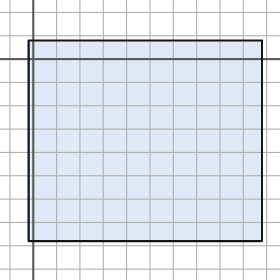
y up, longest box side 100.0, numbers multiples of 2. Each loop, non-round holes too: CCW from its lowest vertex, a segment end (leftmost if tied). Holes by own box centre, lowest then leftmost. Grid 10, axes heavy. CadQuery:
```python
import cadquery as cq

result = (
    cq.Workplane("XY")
    .moveTo(-2.0, -78.0)
    .lineTo(98.0, -78.0)
    .lineTo(98.0, 8.0)
    .lineTo(-2.0, 8.0)
    .close()
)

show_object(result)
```